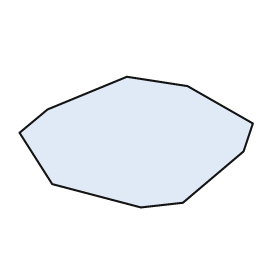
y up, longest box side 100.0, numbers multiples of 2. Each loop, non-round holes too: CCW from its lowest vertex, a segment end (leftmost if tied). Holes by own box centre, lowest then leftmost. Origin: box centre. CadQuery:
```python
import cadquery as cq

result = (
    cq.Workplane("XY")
    .moveTo(2.0, -28.0)
    .lineTo(20.0, -26.0)
    .lineTo(46.0, -4.0)
    .lineTo(50.0, 8.0)
    .lineTo(22.0, 24.0)
    .lineTo(-4.0, 28.0)
    .lineTo(-38.0, 14.0)
    .lineTo(-50.0, 4.0)
    .lineTo(-36.0, -18.0)
    .close()
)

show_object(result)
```